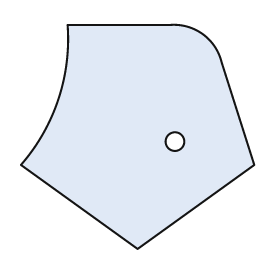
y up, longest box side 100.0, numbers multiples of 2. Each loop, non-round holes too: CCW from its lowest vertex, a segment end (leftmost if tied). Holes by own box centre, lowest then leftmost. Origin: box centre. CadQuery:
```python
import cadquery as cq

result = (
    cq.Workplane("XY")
    .moveTo(0.0, -48.0)
    .lineTo(50.0, -12.0)
    .lineTo(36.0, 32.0)
    .threePointArc((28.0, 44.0), (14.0, 48.0))
    .lineTo(-30.0, 48.0)
    .threePointArc((-34.0, 16.0), (-50.0, -12.0))
    .close()
    .moveTo(16.0, -2.0)
    .circle(4.0)
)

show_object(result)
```